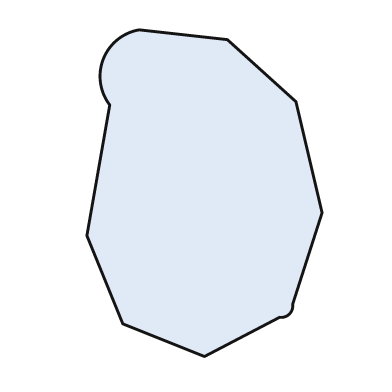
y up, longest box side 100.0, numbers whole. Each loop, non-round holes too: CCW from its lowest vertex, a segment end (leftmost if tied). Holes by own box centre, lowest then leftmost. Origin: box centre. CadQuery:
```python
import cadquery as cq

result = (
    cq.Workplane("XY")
    .moveTo(0.0, -50.0)
    .lineTo(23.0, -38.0)
    .threePointArc((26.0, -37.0), (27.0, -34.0))
    .lineTo(36.0, -6.0)
    .lineTo(28.0, 28.0)
    .lineTo(7.0, 47.0)
    .lineTo(-20.0, 50.0)
    .threePointArc((-31.0, 41.0), (-29.0, 27.0))
    .lineTo(-36.0, -13.0)
    .lineTo(-25.0, -40.0)
    .close()
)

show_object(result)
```